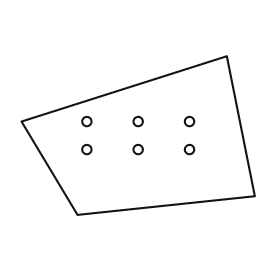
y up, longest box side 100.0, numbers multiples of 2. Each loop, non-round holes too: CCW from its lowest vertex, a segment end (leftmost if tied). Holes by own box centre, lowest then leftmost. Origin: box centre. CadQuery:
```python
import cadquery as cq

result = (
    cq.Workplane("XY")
    .moveTo(-26.0, -34.0)
    .lineTo(50.0, -26.0)
    .lineTo(38.0, 34.0)
    .lineTo(-50.0, 6.0)
    .close()
    .moveTo(-22.0, -6.0)
    .circle(2.0)
    .moveTo(0.0, -6.0)
    .circle(2.0)
    .moveTo(22.0, -6.0)
    .circle(2.0)
    .moveTo(-22.0, 6.0)
    .circle(2.0)
    .moveTo(0.0, 6.0)
    .circle(2.0)
    .moveTo(22.0, 6.0)
    .circle(2.0)
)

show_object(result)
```